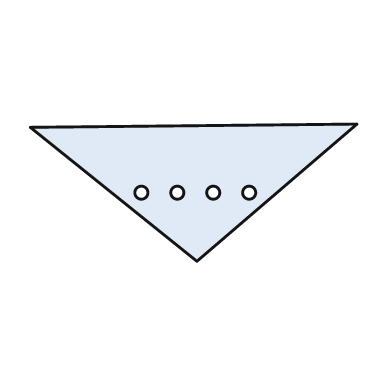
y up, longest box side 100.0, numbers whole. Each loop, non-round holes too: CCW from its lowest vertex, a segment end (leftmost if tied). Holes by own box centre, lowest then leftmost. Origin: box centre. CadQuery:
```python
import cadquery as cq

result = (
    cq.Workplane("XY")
    .moveTo(1.0, -21.0)
    .lineTo(50.0, 21.0)
    .lineTo(-50.0, 20.0)
    .close()
    .moveTo(-16.0, 0.0)
    .circle(2.0)
    .moveTo(-5.0, 0.0)
    .circle(2.0)
    .moveTo(6.0, 0.0)
    .circle(2.0)
    .moveTo(17.0, 0.0)
    .circle(2.0)
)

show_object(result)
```